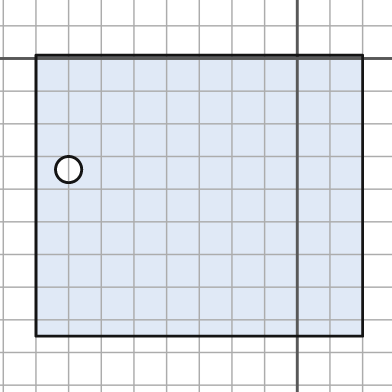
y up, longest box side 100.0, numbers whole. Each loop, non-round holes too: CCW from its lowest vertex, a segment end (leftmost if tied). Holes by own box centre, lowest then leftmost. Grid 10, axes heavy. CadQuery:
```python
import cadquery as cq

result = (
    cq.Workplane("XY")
    .moveTo(-80.0, -85.0)
    .lineTo(20.0, -85.0)
    .lineTo(20.0, 1.0)
    .lineTo(-80.0, 1.0)
    .close()
    .moveTo(-70.0, -34.0)
    .circle(4.0)
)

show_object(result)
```